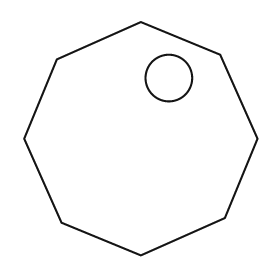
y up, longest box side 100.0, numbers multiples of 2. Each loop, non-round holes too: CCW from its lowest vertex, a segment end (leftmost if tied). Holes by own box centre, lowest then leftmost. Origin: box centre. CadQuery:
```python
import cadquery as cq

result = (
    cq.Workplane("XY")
    .moveTo(0.0, -50.0)
    .lineTo(36.0, -34.0)
    .lineTo(50.0, 0.0)
    .lineTo(34.0, 36.0)
    .lineTo(0.0, 50.0)
    .lineTo(-36.0, 34.0)
    .lineTo(-50.0, 0.0)
    .lineTo(-34.0, -36.0)
    .close()
    .moveTo(12.0, 26.0)
    .circle(10.0)
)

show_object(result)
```